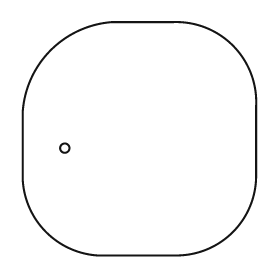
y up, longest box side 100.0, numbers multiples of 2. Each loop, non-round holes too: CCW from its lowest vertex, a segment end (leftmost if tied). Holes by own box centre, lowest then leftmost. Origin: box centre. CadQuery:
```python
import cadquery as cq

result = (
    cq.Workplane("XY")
    .moveTo(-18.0, -50.0)
    .lineTo(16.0, -50.0)
    .threePointArc((40.0, -40.0), (50.0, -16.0))
    .lineTo(50.0, 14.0)
    .threePointArc((40.0, 40.0), (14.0, 50.0))
    .lineTo(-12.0, 50.0)
    .threePointArc((-38.0, 38.0), (-50.0, 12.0))
    .lineTo(-50.0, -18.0)
    .threePointArc((-40.0, -40.0), (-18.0, -50.0))
    .close()
    .moveTo(-32.0, -4.0)
    .circle(2.0)
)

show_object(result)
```